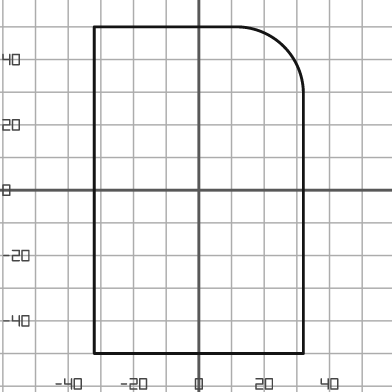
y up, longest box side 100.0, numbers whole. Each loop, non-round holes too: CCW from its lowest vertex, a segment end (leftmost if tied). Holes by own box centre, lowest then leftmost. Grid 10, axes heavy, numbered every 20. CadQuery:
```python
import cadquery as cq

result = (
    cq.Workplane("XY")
    .moveTo(-32.0, -50.0)
    .lineTo(32.0, -50.0)
    .lineTo(32.0, 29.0)
    .threePointArc((26.0, 44.0), (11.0, 50.0))
    .lineTo(-32.0, 50.0)
    .close()
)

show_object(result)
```